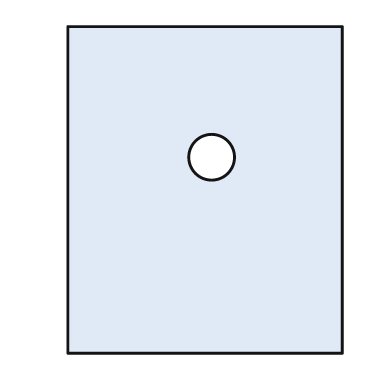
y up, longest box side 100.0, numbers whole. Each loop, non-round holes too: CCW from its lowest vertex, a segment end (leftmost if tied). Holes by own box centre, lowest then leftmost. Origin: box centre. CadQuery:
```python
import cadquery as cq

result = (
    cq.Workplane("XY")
    .moveTo(-42.0, -50.0)
    .lineTo(42.0, -50.0)
    .lineTo(42.0, 50.0)
    .lineTo(-42.0, 50.0)
    .close()
    .moveTo(2.0, 10.0)
    .circle(7.0)
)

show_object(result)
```